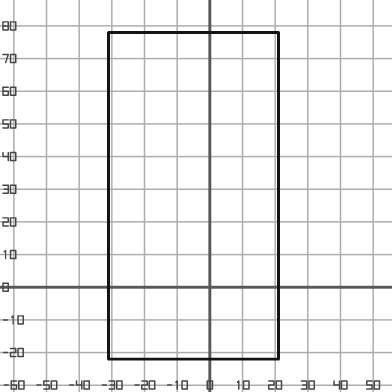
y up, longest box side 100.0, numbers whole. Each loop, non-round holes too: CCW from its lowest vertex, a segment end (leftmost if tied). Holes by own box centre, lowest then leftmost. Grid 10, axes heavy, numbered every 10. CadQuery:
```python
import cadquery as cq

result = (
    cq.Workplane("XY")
    .moveTo(-31.0, -22.0)
    .lineTo(21.0, -22.0)
    .lineTo(21.0, 78.0)
    .lineTo(-31.0, 78.0)
    .close()
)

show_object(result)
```